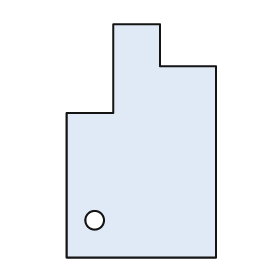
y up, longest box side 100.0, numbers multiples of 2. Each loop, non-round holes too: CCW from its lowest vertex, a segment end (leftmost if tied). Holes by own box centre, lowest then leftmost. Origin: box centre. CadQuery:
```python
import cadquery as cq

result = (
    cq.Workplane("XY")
    .moveTo(-32.0, -50.0)
    .lineTo(32.0, -50.0)
    .lineTo(32.0, 32.0)
    .lineTo(8.0, 32.0)
    .lineTo(8.0, 50.0)
    .lineTo(-12.0, 50.0)
    .lineTo(-12.0, 12.0)
    .lineTo(-32.0, 12.0)
    .close()
    .moveTo(-20.0, -34.0)
    .circle(4.0)
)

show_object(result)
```